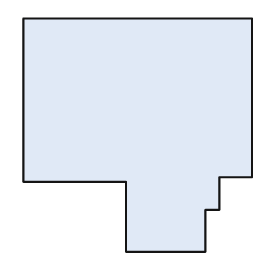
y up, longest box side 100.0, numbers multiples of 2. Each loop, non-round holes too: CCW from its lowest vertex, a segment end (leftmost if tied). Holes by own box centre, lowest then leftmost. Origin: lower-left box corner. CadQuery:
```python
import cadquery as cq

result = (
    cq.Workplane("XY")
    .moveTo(44.0, 0.0)
    .lineTo(78.0, 0.0)
    .lineTo(78.0, 18.0)
    .lineTo(84.0, 18.0)
    .lineTo(84.0, 32.0)
    .lineTo(98.0, 32.0)
    .lineTo(98.0, 100.0)
    .lineTo(0.0, 100.0)
    .lineTo(0.0, 30.0)
    .lineTo(44.0, 30.0)
    .close()
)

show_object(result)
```